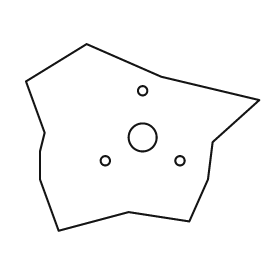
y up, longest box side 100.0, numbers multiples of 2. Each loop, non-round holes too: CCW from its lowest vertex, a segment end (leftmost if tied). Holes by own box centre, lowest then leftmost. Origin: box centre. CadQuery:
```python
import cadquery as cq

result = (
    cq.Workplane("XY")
    .moveTo(-36.0, -40.0)
    .lineTo(-6.0, -32.0)
    .lineTo(20.0, -36.0)
    .lineTo(28.0, -18.0)
    .lineTo(30.0, -2.0)
    .lineTo(50.0, 16.0)
    .lineTo(8.0, 26.0)
    .lineTo(-24.0, 40.0)
    .lineTo(-50.0, 24.0)
    .lineTo(-42.0, 2.0)
    .lineTo(-44.0, -6.0)
    .lineTo(-44.0, -18.0)
    .close()
    .moveTo(-16.0, -10.0)
    .circle(2.0)
    .moveTo(16.0, -10.0)
    .circle(2.0)
    .moveTo(0.0, 0.0)
    .circle(6.0)
    .moveTo(0.0, 20.0)
    .circle(2.0)
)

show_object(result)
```